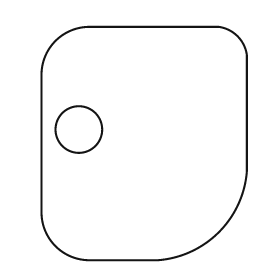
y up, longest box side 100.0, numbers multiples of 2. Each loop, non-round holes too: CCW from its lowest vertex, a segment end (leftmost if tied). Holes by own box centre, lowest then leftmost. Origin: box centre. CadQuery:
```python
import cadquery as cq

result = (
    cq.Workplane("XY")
    .moveTo(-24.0, -50.0)
    .lineTo(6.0, -50.0)
    .threePointArc((32.0, -38.0), (44.0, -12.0))
    .lineTo(44.0, 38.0)
    .threePointArc((40.0, 46.0), (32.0, 50.0))
    .lineTo(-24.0, 50.0)
    .threePointArc((-38.0, 44.0), (-44.0, 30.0))
    .lineTo(-44.0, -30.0)
    .threePointArc((-38.0, -44.0), (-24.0, -50.0))
    .close()
    .moveTo(-28.0, 6.0)
    .circle(10.0)
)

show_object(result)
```